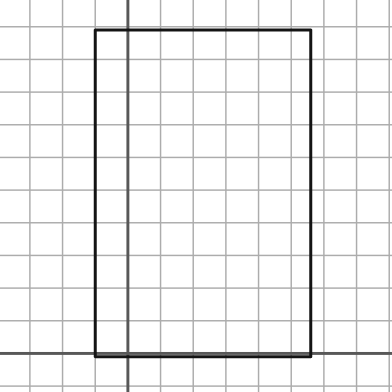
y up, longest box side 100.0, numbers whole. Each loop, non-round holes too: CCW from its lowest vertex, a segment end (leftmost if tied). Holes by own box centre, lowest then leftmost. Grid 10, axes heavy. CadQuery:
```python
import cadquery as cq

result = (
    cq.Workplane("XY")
    .moveTo(-10.0, -1.0)
    .lineTo(56.0, -1.0)
    .lineTo(56.0, 99.0)
    .lineTo(-10.0, 99.0)
    .close()
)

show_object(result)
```